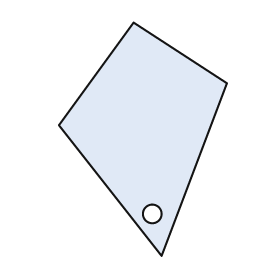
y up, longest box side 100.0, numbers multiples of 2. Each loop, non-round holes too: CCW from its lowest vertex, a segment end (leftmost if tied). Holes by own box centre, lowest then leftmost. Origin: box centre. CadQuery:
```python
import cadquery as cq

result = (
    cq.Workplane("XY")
    .moveTo(8.0, -50.0)
    .lineTo(36.0, 24.0)
    .lineTo(-4.0, 50.0)
    .lineTo(-36.0, 6.0)
    .close()
    .moveTo(4.0, -32.0)
    .circle(4.0)
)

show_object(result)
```